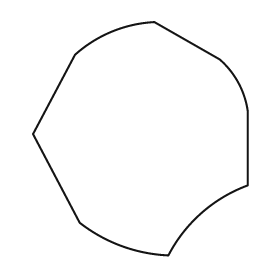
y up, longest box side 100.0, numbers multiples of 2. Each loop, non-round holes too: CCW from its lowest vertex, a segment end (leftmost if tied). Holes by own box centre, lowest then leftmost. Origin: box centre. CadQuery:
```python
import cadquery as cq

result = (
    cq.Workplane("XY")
    .moveTo(12.0, -50.0)
    .threePointArc((26.0, -32.0), (46.0, -20.0))
    .lineTo(46.0, 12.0)
    .threePointArc((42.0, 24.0), (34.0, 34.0))
    .lineTo(6.0, 50.0)
    .threePointArc((-12.0, 46.0), (-28.0, 36.0))
    .lineTo(-46.0, 2.0)
    .lineTo(-26.0, -36.0)
    .threePointArc((-8.0, -46.0), (12.0, -50.0))
    .close()
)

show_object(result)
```